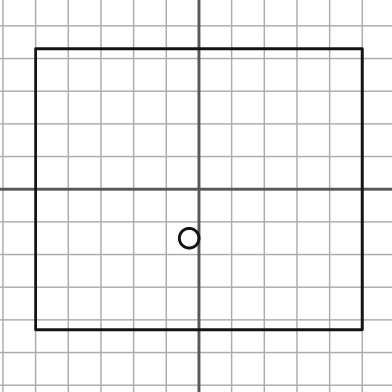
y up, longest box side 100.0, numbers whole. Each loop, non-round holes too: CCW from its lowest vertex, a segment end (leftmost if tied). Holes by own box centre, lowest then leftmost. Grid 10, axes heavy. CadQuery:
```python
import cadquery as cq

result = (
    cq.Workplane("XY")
    .moveTo(-50.0, -43.0)
    .lineTo(50.0, -43.0)
    .lineTo(50.0, 43.0)
    .lineTo(-50.0, 43.0)
    .close()
    .moveTo(-3.0, -15.0)
    .circle(3.0)
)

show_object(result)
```